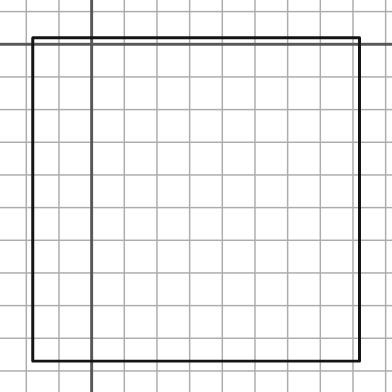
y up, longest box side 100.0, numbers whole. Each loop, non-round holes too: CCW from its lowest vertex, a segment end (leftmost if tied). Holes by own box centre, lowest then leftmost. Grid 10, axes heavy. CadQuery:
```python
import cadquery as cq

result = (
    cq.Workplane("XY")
    .moveTo(-18.0, -97.0)
    .lineTo(82.0, -97.0)
    .lineTo(82.0, 2.0)
    .lineTo(-18.0, 2.0)
    .close()
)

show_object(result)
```